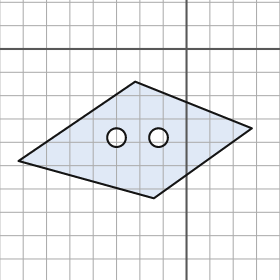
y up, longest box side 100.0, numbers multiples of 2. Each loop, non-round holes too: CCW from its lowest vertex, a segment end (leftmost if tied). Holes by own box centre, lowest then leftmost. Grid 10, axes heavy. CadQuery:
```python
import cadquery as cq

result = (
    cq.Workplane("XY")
    .moveTo(-14.0, -64.0)
    .lineTo(28.0, -34.0)
    .lineTo(-22.0, -14.0)
    .lineTo(-72.0, -48.0)
    .close()
    .moveTo(-30.0, -38.0)
    .circle(4.0)
    .moveTo(-12.0, -38.0)
    .circle(4.0)
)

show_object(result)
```